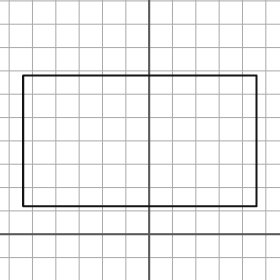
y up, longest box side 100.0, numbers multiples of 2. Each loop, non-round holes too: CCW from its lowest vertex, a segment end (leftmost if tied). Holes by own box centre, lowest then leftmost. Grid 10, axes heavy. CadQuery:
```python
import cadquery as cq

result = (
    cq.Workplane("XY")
    .moveTo(-54.0, 12.0)
    .lineTo(46.0, 12.0)
    .lineTo(46.0, 68.0)
    .lineTo(-54.0, 68.0)
    .close()
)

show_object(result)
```